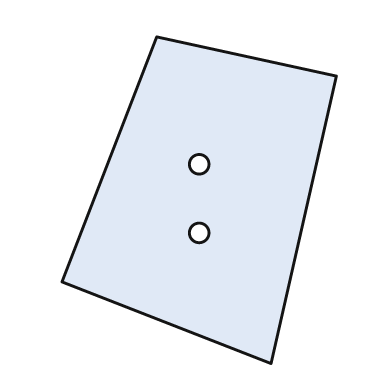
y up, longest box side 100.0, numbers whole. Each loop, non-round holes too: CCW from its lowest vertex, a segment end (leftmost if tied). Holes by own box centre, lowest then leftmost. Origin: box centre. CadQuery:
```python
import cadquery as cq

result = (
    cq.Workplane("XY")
    .moveTo(22.0, -50.0)
    .lineTo(42.0, 38.0)
    .lineTo(-13.0, 50.0)
    .lineTo(-42.0, -25.0)
    .close()
    .moveTo(0.0, -10.0)
    .circle(3.0)
    .moveTo(0.0, 11.0)
    .circle(3.0)
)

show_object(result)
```